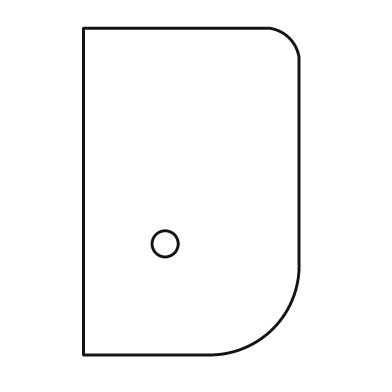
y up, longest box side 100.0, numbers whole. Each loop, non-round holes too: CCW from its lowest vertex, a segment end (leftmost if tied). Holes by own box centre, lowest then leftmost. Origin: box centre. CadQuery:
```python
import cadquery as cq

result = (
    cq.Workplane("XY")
    .moveTo(-33.0, -50.0)
    .lineTo(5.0, -50.0)
    .threePointArc((25.0, -42.0), (33.0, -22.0))
    .lineTo(33.0, 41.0)
    .threePointArc((30.0, 47.0), (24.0, 50.0))
    .lineTo(-33.0, 50.0)
    .close()
    .moveTo(-8.0, -16.0)
    .circle(4.0)
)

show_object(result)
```